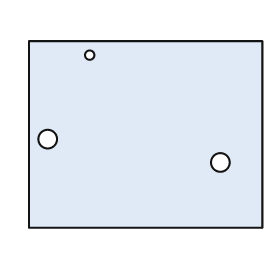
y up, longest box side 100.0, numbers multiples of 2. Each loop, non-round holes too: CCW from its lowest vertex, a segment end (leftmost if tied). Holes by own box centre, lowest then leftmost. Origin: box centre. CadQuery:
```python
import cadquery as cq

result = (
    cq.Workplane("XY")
    .moveTo(-50.0, -40.0)
    .lineTo(50.0, -40.0)
    .lineTo(50.0, 40.0)
    .lineTo(-50.0, 40.0)
    .close()
    .moveTo(32.0, -12.0)
    .circle(4.0)
    .moveTo(-42.0, -2.0)
    .circle(4.0)
    .moveTo(-24.0, 34.0)
    .circle(2.0)
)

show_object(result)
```